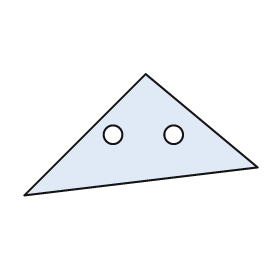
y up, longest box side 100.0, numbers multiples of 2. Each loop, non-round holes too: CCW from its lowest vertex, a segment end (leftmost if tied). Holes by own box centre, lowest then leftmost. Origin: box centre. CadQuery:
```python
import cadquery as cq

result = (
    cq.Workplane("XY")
    .moveTo(-50.0, -26.0)
    .lineTo(50.0, -14.0)
    .lineTo(2.0, 26.0)
    .close()
    .moveTo(-12.0, 0.0)
    .circle(4.0)
    .moveTo(14.0, 0.0)
    .circle(4.0)
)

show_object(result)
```